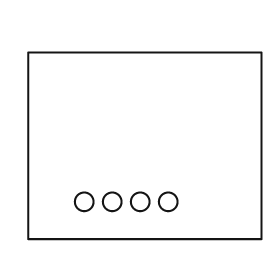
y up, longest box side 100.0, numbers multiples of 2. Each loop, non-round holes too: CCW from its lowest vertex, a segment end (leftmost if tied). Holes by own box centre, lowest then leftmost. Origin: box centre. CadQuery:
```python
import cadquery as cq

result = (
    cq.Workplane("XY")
    .moveTo(-50.0, -40.0)
    .lineTo(50.0, -40.0)
    .lineTo(50.0, 40.0)
    .lineTo(-50.0, 40.0)
    .close()
    .moveTo(-26.0, -24.0)
    .circle(4.0)
    .moveTo(-14.0, -24.0)
    .circle(4.0)
    .moveTo(-2.0, -24.0)
    .circle(4.0)
    .moveTo(10.0, -24.0)
    .circle(4.0)
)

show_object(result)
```